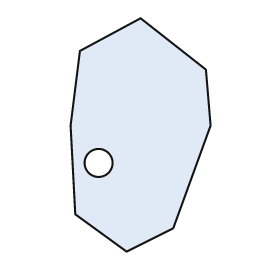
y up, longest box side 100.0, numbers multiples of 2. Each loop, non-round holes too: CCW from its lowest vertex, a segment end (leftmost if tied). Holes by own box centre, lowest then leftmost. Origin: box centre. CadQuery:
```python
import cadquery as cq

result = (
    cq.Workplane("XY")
    .moveTo(-6.0, -50.0)
    .lineTo(14.0, -40.0)
    .lineTo(30.0, 4.0)
    .lineTo(28.0, 28.0)
    .lineTo(0.0, 50.0)
    .lineTo(-26.0, 36.0)
    .lineTo(-30.0, 4.0)
    .lineTo(-28.0, -34.0)
    .close()
    .moveTo(-18.0, -12.0)
    .circle(6.0)
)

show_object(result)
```